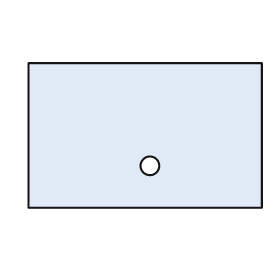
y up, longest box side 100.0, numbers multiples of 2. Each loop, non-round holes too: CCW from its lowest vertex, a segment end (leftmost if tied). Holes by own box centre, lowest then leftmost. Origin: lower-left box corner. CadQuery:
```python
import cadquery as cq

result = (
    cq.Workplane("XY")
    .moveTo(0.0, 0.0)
    .lineTo(100.0, 0.0)
    .lineTo(100.0, 62.0)
    .lineTo(0.0, 62.0)
    .close()
    .moveTo(52.0, 18.0)
    .circle(4.0)
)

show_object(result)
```